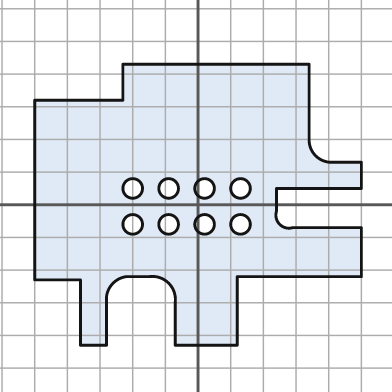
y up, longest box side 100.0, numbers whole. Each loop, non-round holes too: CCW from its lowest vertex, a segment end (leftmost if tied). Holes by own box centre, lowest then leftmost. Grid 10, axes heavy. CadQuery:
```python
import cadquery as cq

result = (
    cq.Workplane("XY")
    .moveTo(-36.0, -43.0)
    .lineTo(-28.0, -43.0)
    .lineTo(-28.0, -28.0)
    .threePointArc((-26.0, -24.0), (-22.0, -22.0))
    .lineTo(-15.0, -22.0)
    .threePointArc((-9.0, -24.0), (-7.0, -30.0))
    .lineTo(-7.0, -43.0)
    .lineTo(12.0, -43.0)
    .lineTo(12.0, -22.0)
    .lineTo(50.0, -22.0)
    .lineTo(50.0, -7.0)
    .lineTo(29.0, -7.0)
    .threePointArc((25.0, -6.0), (24.0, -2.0))
    .lineTo(24.0, 5.0)
    .lineTo(50.0, 5.0)
    .lineTo(50.0, 13.0)
    .lineTo(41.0, 13.0)
    .threePointArc((36.0, 15.0), (34.0, 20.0))
    .lineTo(34.0, 43.0)
    .lineTo(-23.0, 43.0)
    .lineTo(-23.0, 32.0)
    .lineTo(-50.0, 32.0)
    .lineTo(-50.0, -23.0)
    .lineTo(-36.0, -23.0)
    .close()
    .moveTo(-20.0, -6.0)
    .circle(3.0)
    .moveTo(-9.0, -6.0)
    .circle(3.0)
    .moveTo(2.0, -6.0)
    .circle(3.0)
    .moveTo(13.0, -6.0)
    .circle(3.0)
    .moveTo(-20.0, 5.0)
    .circle(3.0)
    .moveTo(-9.0, 5.0)
    .circle(3.0)
    .moveTo(2.0, 5.0)
    .circle(3.0)
    .moveTo(13.0, 5.0)
    .circle(3.0)
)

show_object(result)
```